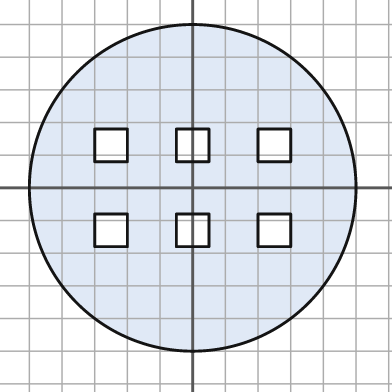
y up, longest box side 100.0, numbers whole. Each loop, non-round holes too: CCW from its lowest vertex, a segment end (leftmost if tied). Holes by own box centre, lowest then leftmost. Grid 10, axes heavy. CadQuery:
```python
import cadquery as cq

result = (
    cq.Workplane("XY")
    .moveTo(0.0, 0.0)
    .circle(50.0)
    .moveTo(-30.0, -18.0)
    .lineTo(-20.0, -18.0)
    .lineTo(-20.0, -8.0)
    .lineTo(-30.0, -8.0)
    .close()
    .moveTo(-5.0, -18.0)
    .lineTo(5.0, -18.0)
    .lineTo(5.0, -8.0)
    .lineTo(-5.0, -8.0)
    .close()
    .moveTo(20.0, -18.0)
    .lineTo(30.0, -18.0)
    .lineTo(30.0, -8.0)
    .lineTo(20.0, -8.0)
    .close()
    .moveTo(-30.0, 8.0)
    .lineTo(-20.0, 8.0)
    .lineTo(-20.0, 18.0)
    .lineTo(-30.0, 18.0)
    .close()
    .moveTo(-5.0, 8.0)
    .lineTo(5.0, 8.0)
    .lineTo(5.0, 18.0)
    .lineTo(-5.0, 18.0)
    .close()
    .moveTo(20.0, 8.0)
    .lineTo(30.0, 8.0)
    .lineTo(30.0, 18.0)
    .lineTo(20.0, 18.0)
    .close()
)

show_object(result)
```